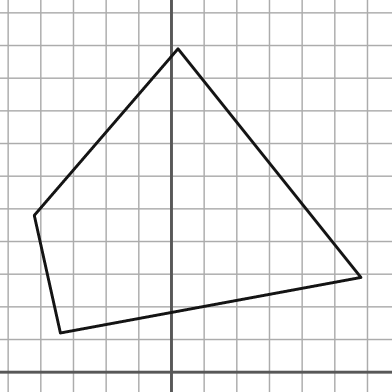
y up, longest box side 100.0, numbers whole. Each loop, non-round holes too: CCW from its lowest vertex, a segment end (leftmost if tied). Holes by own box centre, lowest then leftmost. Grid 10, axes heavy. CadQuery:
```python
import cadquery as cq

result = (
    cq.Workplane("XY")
    .moveTo(-34.0, 12.0)
    .lineTo(58.0, 29.0)
    .lineTo(2.0, 99.0)
    .lineTo(-42.0, 48.0)
    .close()
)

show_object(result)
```